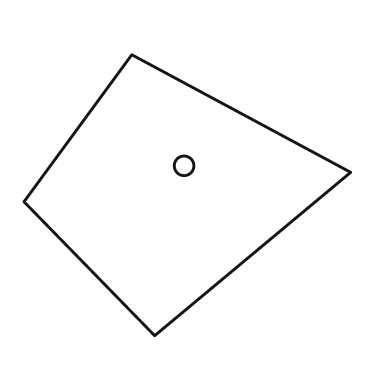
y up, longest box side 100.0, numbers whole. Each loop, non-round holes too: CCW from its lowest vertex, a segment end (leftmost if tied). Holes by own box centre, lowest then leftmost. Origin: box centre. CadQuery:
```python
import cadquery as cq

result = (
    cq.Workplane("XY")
    .moveTo(-10.0, -43.0)
    .lineTo(50.0, 7.0)
    .lineTo(-17.0, 43.0)
    .lineTo(-50.0, -2.0)
    .close()
    .moveTo(-1.0, 9.0)
    .circle(3.0)
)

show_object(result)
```